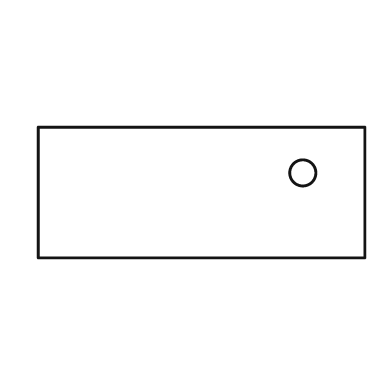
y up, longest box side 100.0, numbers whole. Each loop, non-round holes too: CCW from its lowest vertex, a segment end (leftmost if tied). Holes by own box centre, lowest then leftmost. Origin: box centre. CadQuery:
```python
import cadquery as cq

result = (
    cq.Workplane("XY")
    .moveTo(-50.0, -20.0)
    .lineTo(50.0, -20.0)
    .lineTo(50.0, 20.0)
    .lineTo(-50.0, 20.0)
    .close()
    .moveTo(31.0, 6.0)
    .circle(4.0)
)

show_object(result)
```